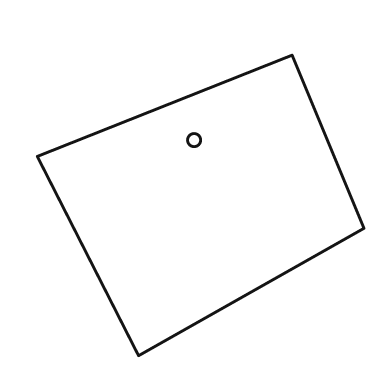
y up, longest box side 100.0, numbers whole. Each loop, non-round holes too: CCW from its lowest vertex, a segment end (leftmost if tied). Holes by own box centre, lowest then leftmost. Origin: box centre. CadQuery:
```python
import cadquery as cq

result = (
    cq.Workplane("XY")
    .moveTo(-19.0, -46.0)
    .lineTo(50.0, -7.0)
    .lineTo(28.0, 46.0)
    .lineTo(-50.0, 15.0)
    .close()
    .moveTo(-2.0, 20.0)
    .circle(2.0)
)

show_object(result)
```